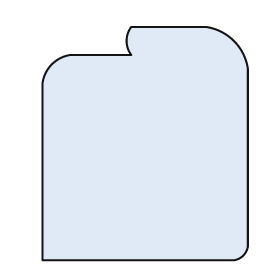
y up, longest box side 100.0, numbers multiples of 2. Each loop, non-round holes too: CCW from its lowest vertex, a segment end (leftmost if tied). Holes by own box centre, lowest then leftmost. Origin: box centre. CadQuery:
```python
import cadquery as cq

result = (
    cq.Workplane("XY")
    .moveTo(-44.0, -50.0)
    .lineTo(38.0, -50.0)
    .threePointArc((42.0, -48.0), (44.0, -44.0))
    .lineTo(44.0, 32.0)
    .threePointArc((38.0, 44.0), (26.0, 50.0))
    .lineTo(-6.0, 50.0)
    .threePointArc((-8.0, 44.0), (-6.0, 38.0))
    .lineTo(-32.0, 38.0)
    .threePointArc((-40.0, 34.0), (-44.0, 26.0))
    .close()
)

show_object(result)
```